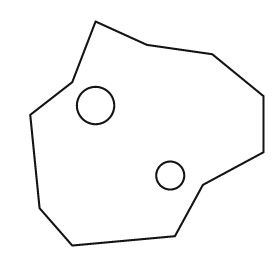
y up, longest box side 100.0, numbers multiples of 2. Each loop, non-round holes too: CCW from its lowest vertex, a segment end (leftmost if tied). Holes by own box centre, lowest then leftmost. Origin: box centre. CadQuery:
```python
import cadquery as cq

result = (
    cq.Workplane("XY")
    .moveTo(-32.0, -48.0)
    .lineTo(12.0, -44.0)
    .lineTo(24.0, -22.0)
    .lineTo(50.0, -8.0)
    .lineTo(50.0, 16.0)
    .lineTo(28.0, 34.0)
    .lineTo(0.0, 38.0)
    .lineTo(-22.0, 48.0)
    .lineTo(-32.0, 22.0)
    .lineTo(-50.0, 8.0)
    .lineTo(-46.0, -32.0)
    .close()
    .moveTo(10.0, -18.0)
    .circle(6.0)
    .moveTo(-22.0, 12.0)
    .circle(8.0)
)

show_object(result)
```